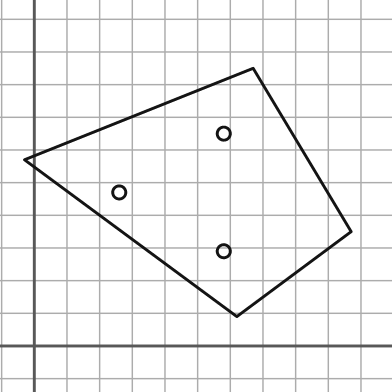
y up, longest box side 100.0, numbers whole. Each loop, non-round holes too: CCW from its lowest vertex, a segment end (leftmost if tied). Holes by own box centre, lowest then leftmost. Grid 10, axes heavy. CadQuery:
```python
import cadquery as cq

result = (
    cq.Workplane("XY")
    .moveTo(62.0, 9.0)
    .lineTo(97.0, 35.0)
    .lineTo(67.0, 85.0)
    .lineTo(-3.0, 57.0)
    .close()
    .moveTo(58.0, 29.0)
    .circle(2.0)
    .moveTo(26.0, 47.0)
    .circle(2.0)
    .moveTo(58.0, 65.0)
    .circle(2.0)
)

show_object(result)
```